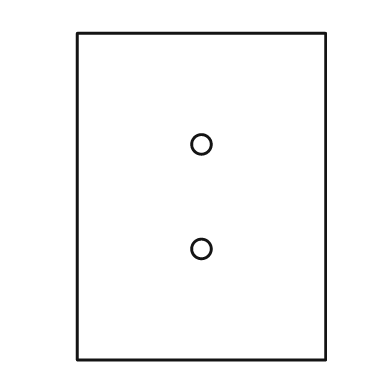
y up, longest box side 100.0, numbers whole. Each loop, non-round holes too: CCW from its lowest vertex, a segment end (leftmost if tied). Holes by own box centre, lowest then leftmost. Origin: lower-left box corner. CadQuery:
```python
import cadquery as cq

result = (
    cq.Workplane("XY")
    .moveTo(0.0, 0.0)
    .lineTo(76.0, 0.0)
    .lineTo(76.0, 100.0)
    .lineTo(0.0, 100.0)
    .close()
    .moveTo(38.0, 34.0)
    .circle(3.0)
    .moveTo(38.0, 66.0)
    .circle(3.0)
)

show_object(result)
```